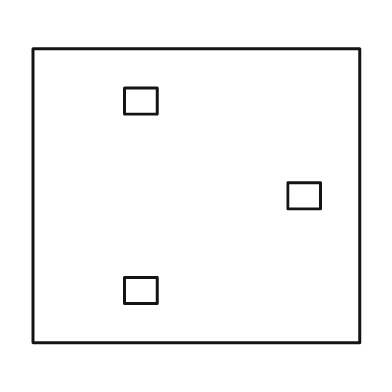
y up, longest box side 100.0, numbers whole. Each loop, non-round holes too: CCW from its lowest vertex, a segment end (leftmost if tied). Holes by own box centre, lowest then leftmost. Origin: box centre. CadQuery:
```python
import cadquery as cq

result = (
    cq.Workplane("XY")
    .moveTo(-50.0, -45.0)
    .lineTo(50.0, -45.0)
    .lineTo(50.0, 45.0)
    .lineTo(-50.0, 45.0)
    .close()
    .moveTo(-22.0, -33.0)
    .lineTo(-12.0, -33.0)
    .lineTo(-12.0, -25.0)
    .lineTo(-22.0, -25.0)
    .close()
    .moveTo(28.0, -4.0)
    .lineTo(38.0, -4.0)
    .lineTo(38.0, 4.0)
    .lineTo(28.0, 4.0)
    .close()
    .moveTo(-22.0, 25.0)
    .lineTo(-12.0, 25.0)
    .lineTo(-12.0, 33.0)
    .lineTo(-22.0, 33.0)
    .close()
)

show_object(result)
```